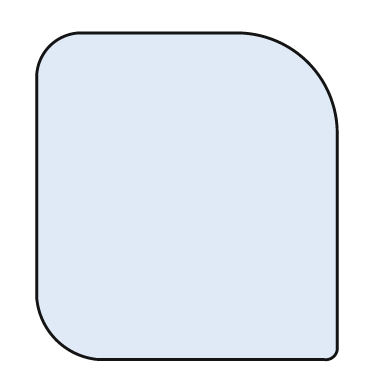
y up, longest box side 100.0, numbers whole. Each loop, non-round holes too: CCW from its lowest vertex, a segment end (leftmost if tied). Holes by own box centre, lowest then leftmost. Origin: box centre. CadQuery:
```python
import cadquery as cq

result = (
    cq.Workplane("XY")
    .moveTo(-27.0, -50.0)
    .lineTo(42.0, -50.0)
    .threePointArc((45.0, -49.0), (46.0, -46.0))
    .lineTo(46.0, 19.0)
    .threePointArc((37.0, 41.0), (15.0, 50.0))
    .lineTo(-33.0, 50.0)
    .threePointArc((-42.0, 46.0), (-46.0, 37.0))
    .lineTo(-46.0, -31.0)
    .threePointArc((-40.0, -44.0), (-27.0, -50.0))
    .close()
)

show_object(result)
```